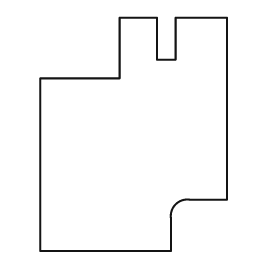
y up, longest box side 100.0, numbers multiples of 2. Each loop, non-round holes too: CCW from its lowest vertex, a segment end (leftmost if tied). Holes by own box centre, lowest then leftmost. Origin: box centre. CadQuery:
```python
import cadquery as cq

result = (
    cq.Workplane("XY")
    .moveTo(-40.0, -50.0)
    .lineTo(16.0, -50.0)
    .lineTo(16.0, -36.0)
    .threePointArc((18.0, -30.0), (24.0, -28.0))
    .lineTo(40.0, -28.0)
    .lineTo(40.0, 50.0)
    .lineTo(18.0, 50.0)
    .lineTo(18.0, 32.0)
    .lineTo(10.0, 32.0)
    .lineTo(10.0, 50.0)
    .lineTo(-6.0, 50.0)
    .lineTo(-6.0, 24.0)
    .lineTo(-40.0, 24.0)
    .close()
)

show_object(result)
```